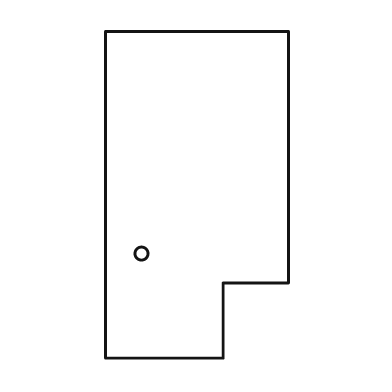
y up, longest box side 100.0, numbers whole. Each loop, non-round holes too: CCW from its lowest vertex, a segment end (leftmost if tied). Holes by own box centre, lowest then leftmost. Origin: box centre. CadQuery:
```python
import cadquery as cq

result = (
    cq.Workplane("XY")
    .moveTo(-28.0, -50.0)
    .lineTo(8.0, -50.0)
    .lineTo(8.0, -27.0)
    .lineTo(28.0, -27.0)
    .lineTo(28.0, 50.0)
    .lineTo(-28.0, 50.0)
    .close()
    .moveTo(-17.0, -18.0)
    .circle(2.0)
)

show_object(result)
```